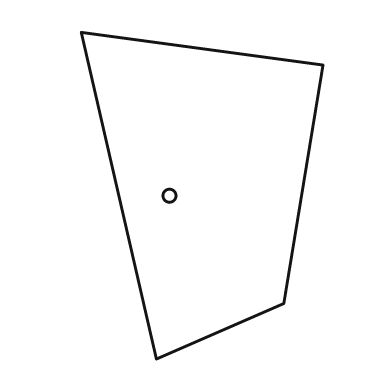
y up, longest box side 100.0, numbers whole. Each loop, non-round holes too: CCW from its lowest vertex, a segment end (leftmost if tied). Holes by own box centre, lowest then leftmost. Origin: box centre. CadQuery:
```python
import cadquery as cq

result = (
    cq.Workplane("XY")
    .moveTo(-14.0, -50.0)
    .lineTo(25.0, -33.0)
    .lineTo(37.0, 40.0)
    .lineTo(-37.0, 50.0)
    .close()
    .moveTo(-10.0, 0.0)
    .circle(2.0)
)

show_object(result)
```